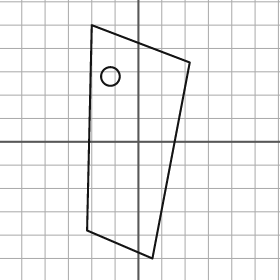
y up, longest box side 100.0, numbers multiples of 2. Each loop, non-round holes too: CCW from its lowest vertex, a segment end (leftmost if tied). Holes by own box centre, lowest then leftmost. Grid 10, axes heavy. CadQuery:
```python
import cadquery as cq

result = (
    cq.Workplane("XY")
    .moveTo(6.0, -50.0)
    .lineTo(22.0, 34.0)
    .lineTo(-20.0, 50.0)
    .lineTo(-22.0, -38.0)
    .close()
    .moveTo(-12.0, 28.0)
    .circle(4.0)
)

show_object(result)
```